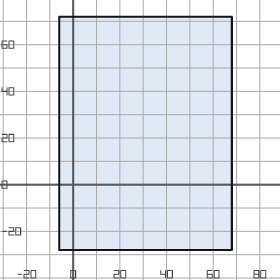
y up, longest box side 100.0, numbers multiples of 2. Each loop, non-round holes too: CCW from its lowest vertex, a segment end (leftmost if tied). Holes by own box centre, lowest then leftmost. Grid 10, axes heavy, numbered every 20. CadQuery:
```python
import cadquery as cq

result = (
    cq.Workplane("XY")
    .moveTo(-6.0, -28.0)
    .lineTo(68.0, -28.0)
    .lineTo(68.0, 72.0)
    .lineTo(-6.0, 72.0)
    .close()
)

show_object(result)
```